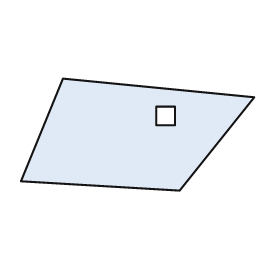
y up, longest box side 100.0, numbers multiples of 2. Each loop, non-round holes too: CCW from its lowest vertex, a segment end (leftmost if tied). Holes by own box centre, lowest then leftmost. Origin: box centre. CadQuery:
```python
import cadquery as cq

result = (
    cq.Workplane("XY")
    .moveTo(18.0, -24.0)
    .lineTo(50.0, 16.0)
    .lineTo(-32.0, 24.0)
    .lineTo(-50.0, -20.0)
    .close()
    .moveTo(8.0, 4.0)
    .lineTo(16.0, 4.0)
    .lineTo(16.0, 12.0)
    .lineTo(8.0, 12.0)
    .close()
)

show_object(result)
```